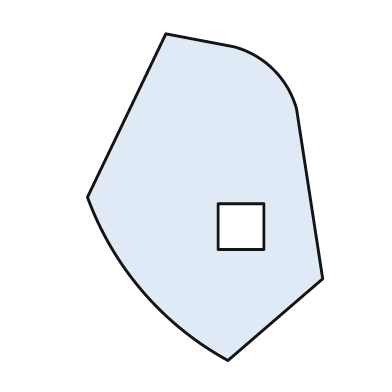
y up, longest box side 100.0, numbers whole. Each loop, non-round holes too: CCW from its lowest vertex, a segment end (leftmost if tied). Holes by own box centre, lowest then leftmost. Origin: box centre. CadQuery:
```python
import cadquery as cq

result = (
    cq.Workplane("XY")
    .moveTo(7.0, -50.0)
    .lineTo(36.0, -25.0)
    .lineTo(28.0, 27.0)
    .threePointArc((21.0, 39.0), (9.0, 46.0))
    .lineTo(-12.0, 50.0)
    .lineTo(-36.0, 0.0)
    .threePointArc((-19.0, -29.0), (7.0, -50.0))
    .close()
    .moveTo(4.0, -16.0)
    .lineTo(18.0, -16.0)
    .lineTo(18.0, -2.0)
    .lineTo(4.0, -2.0)
    .close()
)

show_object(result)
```